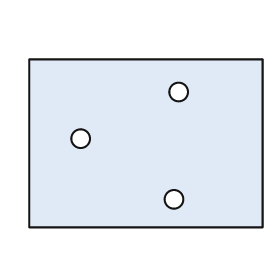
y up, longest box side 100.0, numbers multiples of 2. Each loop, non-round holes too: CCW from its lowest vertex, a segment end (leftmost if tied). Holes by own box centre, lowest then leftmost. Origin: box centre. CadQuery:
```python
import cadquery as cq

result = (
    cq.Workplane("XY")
    .moveTo(-50.0, -36.0)
    .lineTo(50.0, -36.0)
    .lineTo(50.0, 36.0)
    .lineTo(-50.0, 36.0)
    .close()
    .moveTo(12.0, -24.0)
    .circle(4.0)
    .moveTo(-28.0, 2.0)
    .circle(4.0)
    .moveTo(14.0, 22.0)
    .circle(4.0)
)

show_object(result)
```